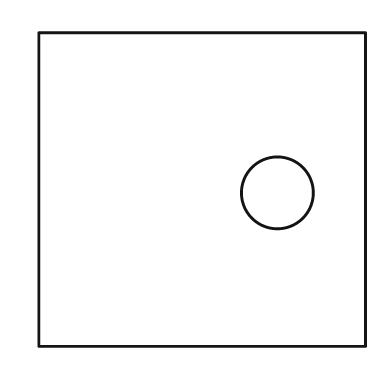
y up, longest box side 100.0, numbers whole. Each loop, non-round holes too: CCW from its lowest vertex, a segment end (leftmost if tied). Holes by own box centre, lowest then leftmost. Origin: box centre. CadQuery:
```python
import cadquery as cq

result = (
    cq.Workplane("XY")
    .moveTo(-50.0, -48.0)
    .lineTo(50.0, -48.0)
    .lineTo(50.0, 48.0)
    .lineTo(-50.0, 48.0)
    .close()
    .moveTo(23.0, -1.0)
    .circle(11.0)
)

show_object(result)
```